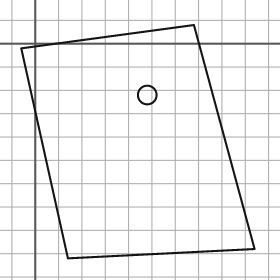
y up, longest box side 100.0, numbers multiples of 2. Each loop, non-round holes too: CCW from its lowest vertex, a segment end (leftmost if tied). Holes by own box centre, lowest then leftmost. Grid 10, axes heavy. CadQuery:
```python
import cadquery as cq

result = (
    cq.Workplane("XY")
    .moveTo(14.0, -92.0)
    .lineTo(94.0, -88.0)
    .lineTo(68.0, 8.0)
    .lineTo(-6.0, -2.0)
    .close()
    .moveTo(48.0, -22.0)
    .circle(4.0)
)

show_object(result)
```